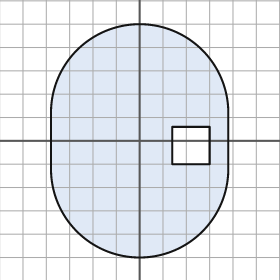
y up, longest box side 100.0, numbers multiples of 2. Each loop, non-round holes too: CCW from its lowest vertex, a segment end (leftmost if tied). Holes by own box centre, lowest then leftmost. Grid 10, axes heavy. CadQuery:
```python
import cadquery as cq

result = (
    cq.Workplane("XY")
    .moveTo(-38.0, -12.0)
    .threePointArc((0.0, -50.0), (38.0, -12.0))
    .lineTo(38.0, 12.0)
    .threePointArc((0.0, 50.0), (-38.0, 12.0))
    .close()
    .moveTo(14.0, -10.0)
    .lineTo(30.0, -10.0)
    .lineTo(30.0, 6.0)
    .lineTo(14.0, 6.0)
    .close()
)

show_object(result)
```